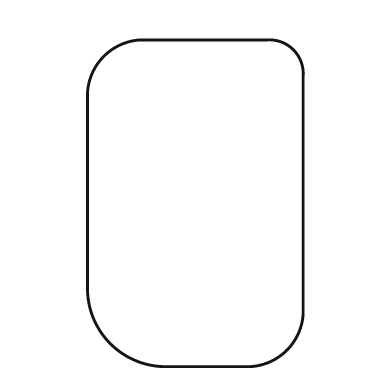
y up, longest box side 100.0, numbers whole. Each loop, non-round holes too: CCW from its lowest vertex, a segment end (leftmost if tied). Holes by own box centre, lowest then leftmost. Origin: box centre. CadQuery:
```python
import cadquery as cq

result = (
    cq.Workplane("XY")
    .moveTo(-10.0, -50.0)
    .lineTo(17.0, -50.0)
    .threePointArc((28.0, -45.0), (33.0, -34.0))
    .lineTo(33.0, 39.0)
    .threePointArc((30.0, 47.0), (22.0, 50.0))
    .lineTo(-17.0, 50.0)
    .threePointArc((-28.0, 45.0), (-33.0, 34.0))
    .lineTo(-33.0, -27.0)
    .threePointArc((-26.0, -43.0), (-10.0, -50.0))
    .close()
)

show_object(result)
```